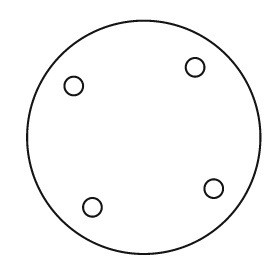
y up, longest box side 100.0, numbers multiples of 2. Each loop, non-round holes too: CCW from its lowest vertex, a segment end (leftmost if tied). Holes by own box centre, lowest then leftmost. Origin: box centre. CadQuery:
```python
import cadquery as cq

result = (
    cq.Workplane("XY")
    .moveTo(0.0, 0.0)
    .circle(50.0)
    .moveTo(-22.0, -30.0)
    .circle(4.0)
    .moveTo(30.0, -22.0)
    .circle(4.0)
    .moveTo(-30.0, 22.0)
    .circle(4.0)
    .moveTo(22.0, 30.0)
    .circle(4.0)
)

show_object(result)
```